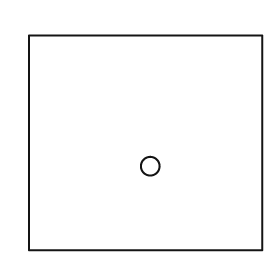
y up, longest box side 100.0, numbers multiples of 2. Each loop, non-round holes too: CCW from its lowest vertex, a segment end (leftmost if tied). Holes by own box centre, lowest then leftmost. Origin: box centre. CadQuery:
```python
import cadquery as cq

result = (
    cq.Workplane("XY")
    .moveTo(-50.0, -46.0)
    .lineTo(50.0, -46.0)
    .lineTo(50.0, 46.0)
    .lineTo(-50.0, 46.0)
    .close()
    .moveTo(2.0, -10.0)
    .circle(4.0)
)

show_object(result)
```